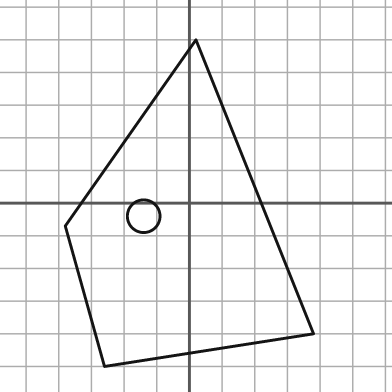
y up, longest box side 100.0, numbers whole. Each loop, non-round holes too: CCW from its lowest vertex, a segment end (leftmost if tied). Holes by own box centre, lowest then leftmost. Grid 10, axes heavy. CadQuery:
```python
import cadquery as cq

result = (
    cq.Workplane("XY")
    .moveTo(-26.0, -50.0)
    .lineTo(38.0, -40.0)
    .lineTo(2.0, 50.0)
    .lineTo(-38.0, -7.0)
    .close()
    .moveTo(-14.0, -4.0)
    .circle(5.0)
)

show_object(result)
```